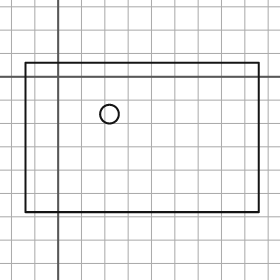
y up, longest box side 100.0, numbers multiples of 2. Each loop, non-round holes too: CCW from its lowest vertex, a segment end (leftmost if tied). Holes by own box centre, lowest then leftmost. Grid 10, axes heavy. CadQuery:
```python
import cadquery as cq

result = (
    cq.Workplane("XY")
    .moveTo(-14.0, -58.0)
    .lineTo(86.0, -58.0)
    .lineTo(86.0, 6.0)
    .lineTo(-14.0, 6.0)
    .close()
    .moveTo(22.0, -16.0)
    .circle(4.0)
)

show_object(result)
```